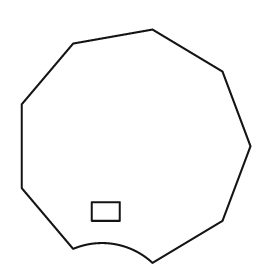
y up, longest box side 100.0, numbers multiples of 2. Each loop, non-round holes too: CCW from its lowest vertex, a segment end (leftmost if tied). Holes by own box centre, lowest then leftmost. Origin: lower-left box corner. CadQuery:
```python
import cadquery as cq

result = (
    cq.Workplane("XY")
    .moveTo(56.0, 0.0)
    .lineTo(86.0, 18.0)
    .lineTo(98.0, 50.0)
    .lineTo(86.0, 82.0)
    .lineTo(56.0, 100.0)
    .lineTo(22.0, 94.0)
    .lineTo(0.0, 68.0)
    .lineTo(0.0, 32.0)
    .lineTo(22.0, 6.0)
    .threePointArc((40.0, 8.0), (56.0, 0.0))
    .close()
    .moveTo(30.0, 18.0)
    .lineTo(42.0, 18.0)
    .lineTo(42.0, 26.0)
    .lineTo(30.0, 26.0)
    .close()
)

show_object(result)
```